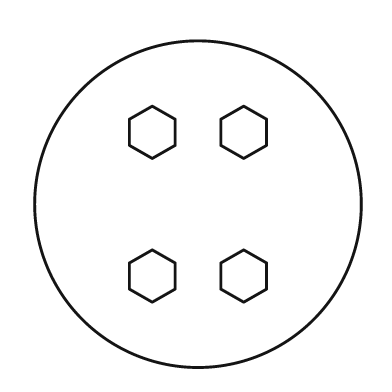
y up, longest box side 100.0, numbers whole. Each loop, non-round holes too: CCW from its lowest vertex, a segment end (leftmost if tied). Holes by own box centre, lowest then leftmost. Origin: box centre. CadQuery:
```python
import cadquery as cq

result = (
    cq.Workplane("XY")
    .moveTo(0.0, 0.0)
    .circle(50.0)
    .moveTo(-14.0, -30.0)
    .lineTo(-7.0, -26.0)
    .lineTo(-7.0, -18.0)
    .lineTo(-14.0, -14.0)
    .lineTo(-21.0, -18.0)
    .lineTo(-21.0, -26.0)
    .close()
    .moveTo(14.0, -30.0)
    .lineTo(21.0, -26.0)
    .lineTo(21.0, -18.0)
    .lineTo(14.0, -14.0)
    .lineTo(7.0, -18.0)
    .lineTo(7.0, -26.0)
    .close()
    .moveTo(-14.0, 14.0)
    .lineTo(-7.0, 18.0)
    .lineTo(-7.0, 26.0)
    .lineTo(-14.0, 30.0)
    .lineTo(-21.0, 26.0)
    .lineTo(-21.0, 18.0)
    .close()
    .moveTo(14.0, 14.0)
    .lineTo(21.0, 18.0)
    .lineTo(21.0, 26.0)
    .lineTo(14.0, 30.0)
    .lineTo(7.0, 26.0)
    .lineTo(7.0, 18.0)
    .close()
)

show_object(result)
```